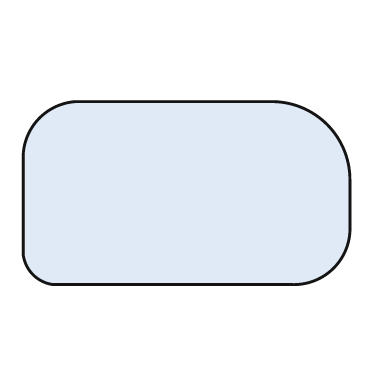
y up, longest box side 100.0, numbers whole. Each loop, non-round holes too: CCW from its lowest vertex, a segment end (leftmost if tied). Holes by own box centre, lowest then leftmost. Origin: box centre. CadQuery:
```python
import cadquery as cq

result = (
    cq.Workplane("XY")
    .moveTo(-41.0, -28.0)
    .lineTo(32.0, -28.0)
    .threePointArc((45.0, -23.0), (50.0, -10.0))
    .lineTo(50.0, 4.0)
    .threePointArc((43.0, 21.0), (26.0, 28.0))
    .lineTo(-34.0, 28.0)
    .threePointArc((-45.0, 23.0), (-50.0, 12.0))
    .lineTo(-50.0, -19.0)
    .threePointArc((-47.0, -25.0), (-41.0, -28.0))
    .close()
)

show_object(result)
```